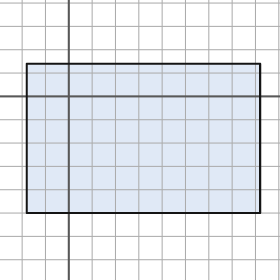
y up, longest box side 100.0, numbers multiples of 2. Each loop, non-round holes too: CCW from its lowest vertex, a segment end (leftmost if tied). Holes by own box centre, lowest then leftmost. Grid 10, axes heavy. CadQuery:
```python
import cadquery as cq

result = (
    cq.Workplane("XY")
    .moveTo(-18.0, -50.0)
    .lineTo(82.0, -50.0)
    .lineTo(82.0, 14.0)
    .lineTo(-18.0, 14.0)
    .close()
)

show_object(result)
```